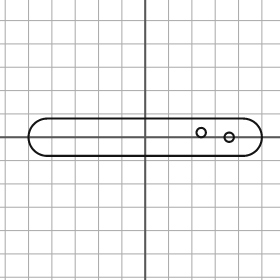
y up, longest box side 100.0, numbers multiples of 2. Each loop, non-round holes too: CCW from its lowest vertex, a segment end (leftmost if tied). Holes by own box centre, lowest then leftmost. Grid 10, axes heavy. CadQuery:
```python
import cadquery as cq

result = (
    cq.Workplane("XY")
    .moveTo(-42.0, -8.0)
    .lineTo(42.0, -8.0)
    .threePointArc((50.0, 0.0), (42.0, 8.0))
    .lineTo(-42.0, 8.0)
    .threePointArc((-50.0, 0.0), (-42.0, -8.0))
    .close()
    .moveTo(36.0, 0.0)
    .circle(2.0)
    .moveTo(24.0, 2.0)
    .circle(2.0)
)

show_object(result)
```